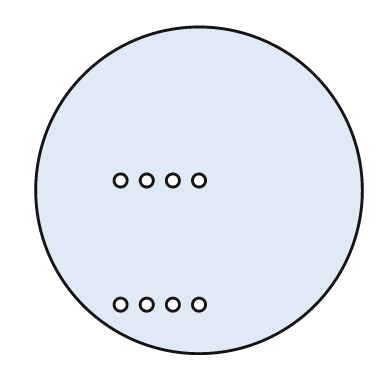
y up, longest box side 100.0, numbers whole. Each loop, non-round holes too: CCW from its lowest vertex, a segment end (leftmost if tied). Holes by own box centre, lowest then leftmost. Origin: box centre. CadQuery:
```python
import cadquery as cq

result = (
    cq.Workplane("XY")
    .moveTo(0.0, 0.0)
    .circle(50.0)
    .moveTo(-24.0, -35.0)
    .circle(2.0)
    .moveTo(-16.0, -35.0)
    .circle(2.0)
    .moveTo(-8.0, -35.0)
    .circle(2.0)
    .moveTo(0.0, -35.0)
    .circle(2.0)
    .moveTo(-24.0, 3.0)
    .circle(2.0)
    .moveTo(-16.0, 3.0)
    .circle(2.0)
    .moveTo(-8.0, 3.0)
    .circle(2.0)
    .moveTo(0.0, 3.0)
    .circle(2.0)
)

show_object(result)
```